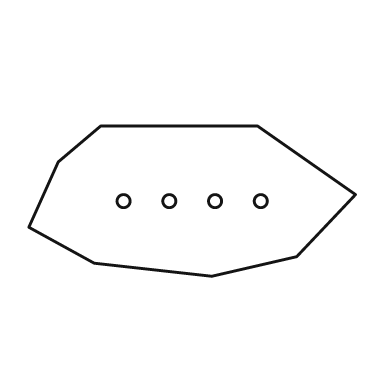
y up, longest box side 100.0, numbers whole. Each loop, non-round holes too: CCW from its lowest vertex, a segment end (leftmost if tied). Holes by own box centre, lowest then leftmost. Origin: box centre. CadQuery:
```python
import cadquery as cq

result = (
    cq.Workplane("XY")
    .moveTo(6.0, -23.0)
    .lineTo(32.0, -17.0)
    .lineTo(50.0, 2.0)
    .lineTo(20.0, 23.0)
    .lineTo(-28.0, 23.0)
    .lineTo(-41.0, 12.0)
    .lineTo(-50.0, -8.0)
    .lineTo(-30.0, -19.0)
    .close()
    .moveTo(-21.0, 0.0)
    .circle(2.0)
    .moveTo(-7.0, 0.0)
    .circle(2.0)
    .moveTo(7.0, 0.0)
    .circle(2.0)
    .moveTo(21.0, 0.0)
    .circle(2.0)
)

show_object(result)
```